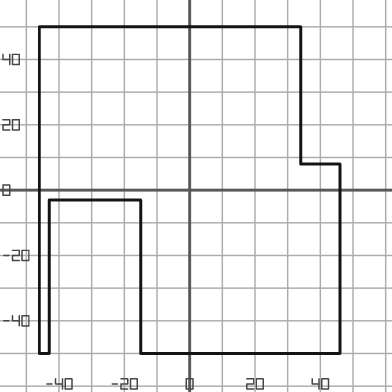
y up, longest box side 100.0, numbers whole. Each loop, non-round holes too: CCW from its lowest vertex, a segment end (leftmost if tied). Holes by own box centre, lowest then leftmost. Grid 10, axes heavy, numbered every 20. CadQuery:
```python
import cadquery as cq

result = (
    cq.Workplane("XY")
    .moveTo(-46.0, -50.0)
    .lineTo(-43.0, -50.0)
    .lineTo(-43.0, -3.0)
    .lineTo(-15.0, -3.0)
    .lineTo(-15.0, -50.0)
    .lineTo(46.0, -50.0)
    .lineTo(46.0, 8.0)
    .lineTo(34.0, 8.0)
    .lineTo(34.0, 50.0)
    .lineTo(-46.0, 50.0)
    .close()
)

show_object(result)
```